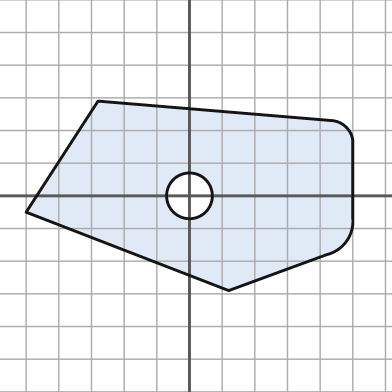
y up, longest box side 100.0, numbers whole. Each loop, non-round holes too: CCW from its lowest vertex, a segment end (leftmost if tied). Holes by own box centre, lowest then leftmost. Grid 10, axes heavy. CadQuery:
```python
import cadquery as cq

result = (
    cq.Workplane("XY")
    .moveTo(12.0, -29.0)
    .lineTo(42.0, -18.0)
    .threePointArc((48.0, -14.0), (50.0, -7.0))
    .lineTo(50.0, 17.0)
    .threePointArc((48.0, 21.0), (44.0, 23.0))
    .lineTo(-28.0, 29.0)
    .lineTo(-50.0, -5.0)
    .close()
    .moveTo(0.0, 0.0)
    .circle(7.0)
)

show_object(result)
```